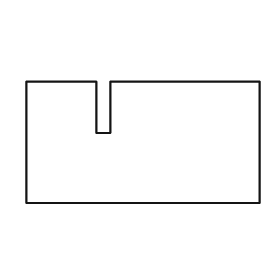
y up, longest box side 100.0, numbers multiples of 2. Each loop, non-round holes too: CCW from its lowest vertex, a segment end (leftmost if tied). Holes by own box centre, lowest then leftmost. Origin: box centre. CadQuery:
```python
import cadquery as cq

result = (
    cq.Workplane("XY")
    .moveTo(-50.0, -26.0)
    .lineTo(50.0, -26.0)
    .lineTo(50.0, 26.0)
    .lineTo(-14.0, 26.0)
    .lineTo(-14.0, 4.0)
    .lineTo(-20.0, 4.0)
    .lineTo(-20.0, 26.0)
    .lineTo(-50.0, 26.0)
    .close()
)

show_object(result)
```